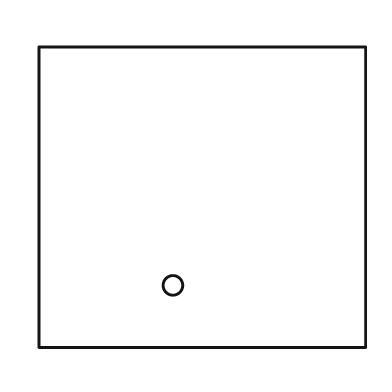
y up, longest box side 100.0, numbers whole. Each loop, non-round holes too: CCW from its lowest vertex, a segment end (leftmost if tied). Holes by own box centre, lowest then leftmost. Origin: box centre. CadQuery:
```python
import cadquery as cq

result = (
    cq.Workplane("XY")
    .moveTo(-50.0, -46.0)
    .lineTo(50.0, -46.0)
    .lineTo(50.0, 46.0)
    .lineTo(-50.0, 46.0)
    .close()
    .moveTo(-9.0, -27.0)
    .circle(3.0)
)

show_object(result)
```